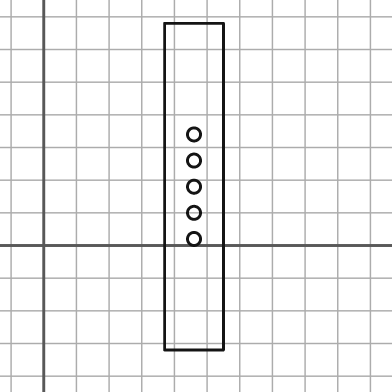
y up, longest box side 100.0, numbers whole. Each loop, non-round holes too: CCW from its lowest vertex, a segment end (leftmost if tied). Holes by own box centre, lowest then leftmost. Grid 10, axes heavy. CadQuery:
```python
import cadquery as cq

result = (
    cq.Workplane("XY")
    .moveTo(37.0, -32.0)
    .lineTo(55.0, -32.0)
    .lineTo(55.0, 68.0)
    .lineTo(37.0, 68.0)
    .close()
    .moveTo(46.0, 2.0)
    .circle(2.0)
    .moveTo(46.0, 10.0)
    .circle(2.0)
    .moveTo(46.0, 18.0)
    .circle(2.0)
    .moveTo(46.0, 26.0)
    .circle(2.0)
    .moveTo(46.0, 34.0)
    .circle(2.0)
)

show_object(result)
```